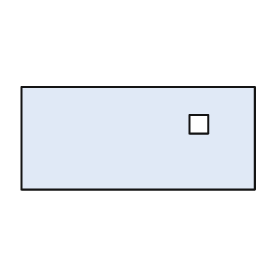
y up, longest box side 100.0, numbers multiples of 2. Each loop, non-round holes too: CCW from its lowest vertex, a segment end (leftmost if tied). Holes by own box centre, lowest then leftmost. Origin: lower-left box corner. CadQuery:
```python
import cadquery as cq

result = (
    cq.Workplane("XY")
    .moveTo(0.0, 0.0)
    .lineTo(100.0, 0.0)
    .lineTo(100.0, 44.0)
    .lineTo(0.0, 44.0)
    .close()
    .moveTo(72.0, 24.0)
    .lineTo(80.0, 24.0)
    .lineTo(80.0, 32.0)
    .lineTo(72.0, 32.0)
    .close()
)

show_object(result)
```